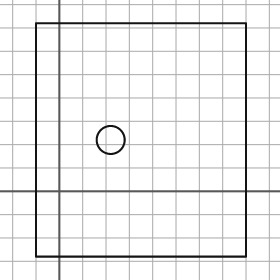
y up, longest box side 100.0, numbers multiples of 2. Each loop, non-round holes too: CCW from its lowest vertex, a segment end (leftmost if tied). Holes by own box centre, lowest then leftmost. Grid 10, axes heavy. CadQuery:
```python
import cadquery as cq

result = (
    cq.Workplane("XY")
    .moveTo(-10.0, -28.0)
    .lineTo(80.0, -28.0)
    .lineTo(80.0, 72.0)
    .lineTo(-10.0, 72.0)
    .close()
    .moveTo(22.0, 22.0)
    .circle(6.0)
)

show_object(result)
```